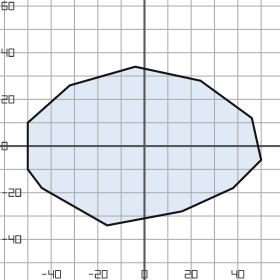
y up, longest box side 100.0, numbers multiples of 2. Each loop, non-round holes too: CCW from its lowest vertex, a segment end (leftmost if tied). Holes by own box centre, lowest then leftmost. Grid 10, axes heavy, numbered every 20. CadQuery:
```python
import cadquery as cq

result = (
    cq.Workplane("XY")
    .moveTo(-16.0, -34.0)
    .lineTo(16.0, -28.0)
    .lineTo(38.0, -18.0)
    .lineTo(50.0, -6.0)
    .lineTo(46.0, 12.0)
    .lineTo(24.0, 28.0)
    .lineTo(-4.0, 34.0)
    .lineTo(-32.0, 26.0)
    .lineTo(-50.0, 10.0)
    .lineTo(-50.0, -10.0)
    .lineTo(-44.0, -18.0)
    .close()
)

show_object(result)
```